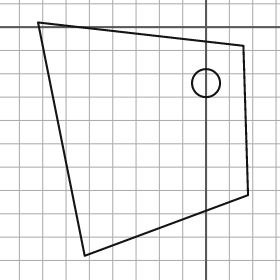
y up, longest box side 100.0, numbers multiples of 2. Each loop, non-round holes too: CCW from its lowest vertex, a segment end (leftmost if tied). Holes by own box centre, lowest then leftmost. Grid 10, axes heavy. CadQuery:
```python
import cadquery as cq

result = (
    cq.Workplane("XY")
    .moveTo(-52.0, -98.0)
    .lineTo(18.0, -72.0)
    .lineTo(16.0, -8.0)
    .lineTo(-72.0, 2.0)
    .close()
    .moveTo(0.0, -24.0)
    .circle(6.0)
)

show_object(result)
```